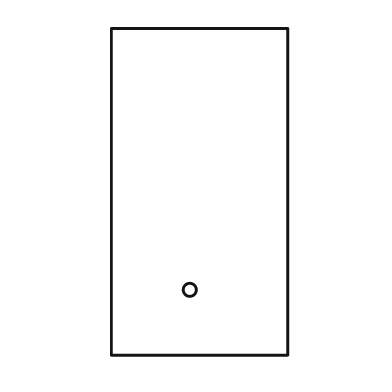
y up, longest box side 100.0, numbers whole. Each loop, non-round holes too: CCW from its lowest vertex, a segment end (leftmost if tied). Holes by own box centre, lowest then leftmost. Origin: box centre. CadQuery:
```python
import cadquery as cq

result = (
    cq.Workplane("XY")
    .moveTo(-27.0, -50.0)
    .lineTo(27.0, -50.0)
    .lineTo(27.0, 50.0)
    .lineTo(-27.0, 50.0)
    .close()
    .moveTo(-3.0, -30.0)
    .circle(2.0)
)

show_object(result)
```